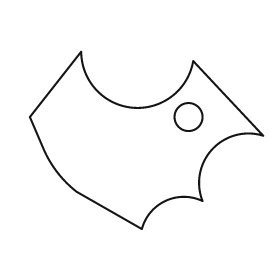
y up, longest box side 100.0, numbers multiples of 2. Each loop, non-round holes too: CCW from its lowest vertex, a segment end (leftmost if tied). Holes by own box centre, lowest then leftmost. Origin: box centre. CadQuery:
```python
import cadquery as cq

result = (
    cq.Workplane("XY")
    .moveTo(-2.0, -38.0)
    .threePointArc((8.0, -26.0), (24.0, -26.0))
    .threePointArc((28.0, -4.0), (50.0, 2.0))
    .lineTo(20.0, 34.0)
    .threePointArc((-6.0, 14.0), (-28.0, 38.0))
    .lineTo(-50.0, 10.0)
    .lineTo(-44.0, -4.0)
    .threePointArc((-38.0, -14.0), (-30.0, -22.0))
    .close()
    .moveTo(18.0, 10.0)
    .circle(6.0)
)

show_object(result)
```